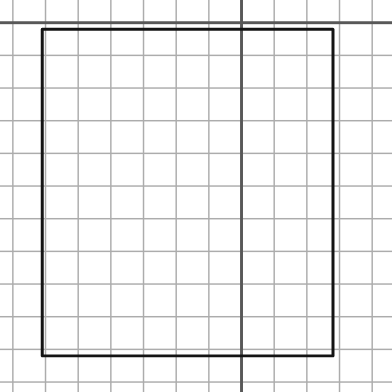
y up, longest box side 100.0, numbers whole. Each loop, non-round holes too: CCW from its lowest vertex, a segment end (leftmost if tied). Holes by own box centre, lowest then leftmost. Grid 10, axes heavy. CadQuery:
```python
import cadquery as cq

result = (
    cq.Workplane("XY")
    .moveTo(-61.0, -102.0)
    .lineTo(28.0, -102.0)
    .lineTo(28.0, -2.0)
    .lineTo(-61.0, -2.0)
    .close()
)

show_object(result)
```